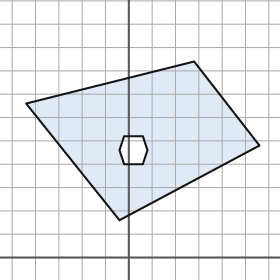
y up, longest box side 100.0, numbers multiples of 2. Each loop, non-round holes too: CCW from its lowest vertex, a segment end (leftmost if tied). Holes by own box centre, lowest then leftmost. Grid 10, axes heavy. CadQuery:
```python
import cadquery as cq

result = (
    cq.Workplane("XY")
    .moveTo(-4.0, 16.0)
    .lineTo(56.0, 48.0)
    .lineTo(28.0, 84.0)
    .lineTo(-44.0, 66.0)
    .close()
    .moveTo(-2.0, 40.0)
    .lineTo(6.0, 40.0)
    .lineTo(8.0, 46.0)
    .lineTo(6.0, 52.0)
    .lineTo(-2.0, 52.0)
    .lineTo(-4.0, 46.0)
    .close()
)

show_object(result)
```